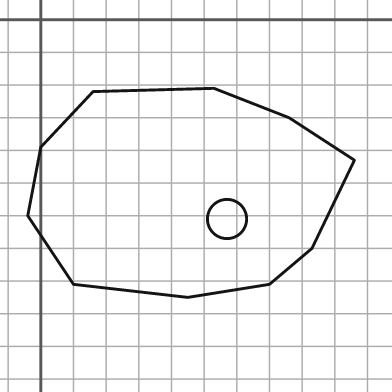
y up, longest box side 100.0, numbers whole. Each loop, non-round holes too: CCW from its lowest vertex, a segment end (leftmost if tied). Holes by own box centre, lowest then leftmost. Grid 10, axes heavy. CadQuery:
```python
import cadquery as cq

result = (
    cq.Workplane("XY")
    .moveTo(45.0, -85.0)
    .lineTo(70.0, -81.0)
    .lineTo(83.0, -70.0)
    .lineTo(96.0, -43.0)
    .lineTo(76.0, -30.0)
    .lineTo(53.0, -21.0)
    .lineTo(16.0, -22.0)
    .lineTo(0.0, -39.0)
    .lineTo(-4.0, -60.0)
    .lineTo(10.0, -81.0)
    .close()
    .moveTo(57.0, -61.0)
    .circle(6.0)
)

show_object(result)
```